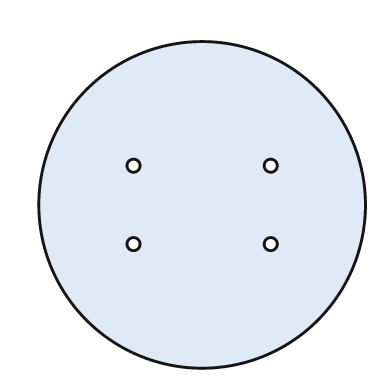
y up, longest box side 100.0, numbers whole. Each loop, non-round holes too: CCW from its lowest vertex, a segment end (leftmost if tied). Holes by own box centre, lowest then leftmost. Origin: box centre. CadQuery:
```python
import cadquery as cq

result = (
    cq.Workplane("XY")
    .moveTo(0.0, 0.0)
    .circle(50.0)
    .moveTo(-21.0, -12.0)
    .circle(2.0)
    .moveTo(21.0, -12.0)
    .circle(2.0)
    .moveTo(-21.0, 12.0)
    .circle(2.0)
    .moveTo(21.0, 12.0)
    .circle(2.0)
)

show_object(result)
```